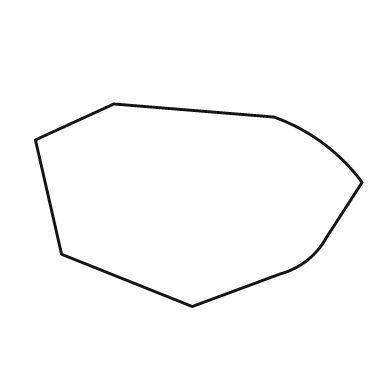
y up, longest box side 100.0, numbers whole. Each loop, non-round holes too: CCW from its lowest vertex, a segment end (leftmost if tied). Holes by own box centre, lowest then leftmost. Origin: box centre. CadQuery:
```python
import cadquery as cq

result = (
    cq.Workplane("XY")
    .moveTo(-2.0, -31.0)
    .lineTo(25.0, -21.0)
    .threePointArc((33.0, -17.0), (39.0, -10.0))
    .lineTo(50.0, 7.0)
    .threePointArc((38.0, 19.0), (23.0, 27.0))
    .lineTo(-26.0, 31.0)
    .lineTo(-50.0, 20.0)
    .lineTo(-42.0, -15.0)
    .close()
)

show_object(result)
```